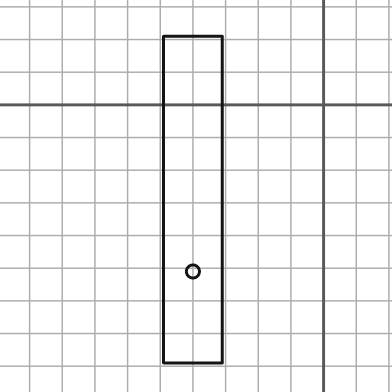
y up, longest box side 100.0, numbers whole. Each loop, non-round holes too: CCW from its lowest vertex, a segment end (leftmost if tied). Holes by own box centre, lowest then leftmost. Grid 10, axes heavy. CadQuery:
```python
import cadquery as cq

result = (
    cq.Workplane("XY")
    .moveTo(-49.0, -79.0)
    .lineTo(-31.0, -79.0)
    .lineTo(-31.0, 21.0)
    .lineTo(-49.0, 21.0)
    .close()
    .moveTo(-40.0, -51.0)
    .circle(2.0)
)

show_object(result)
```